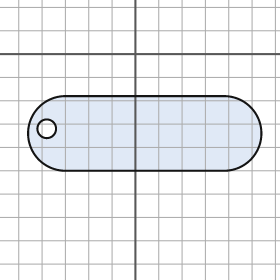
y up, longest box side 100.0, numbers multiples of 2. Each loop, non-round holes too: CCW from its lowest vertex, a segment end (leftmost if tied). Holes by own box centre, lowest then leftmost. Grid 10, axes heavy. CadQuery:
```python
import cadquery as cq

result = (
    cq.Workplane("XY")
    .moveTo(-30.0, -50.0)
    .lineTo(38.0, -50.0)
    .threePointArc((54.0, -34.0), (38.0, -18.0))
    .lineTo(-30.0, -18.0)
    .threePointArc((-46.0, -34.0), (-30.0, -50.0))
    .close()
    .moveTo(-38.0, -32.0)
    .circle(4.0)
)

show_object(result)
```